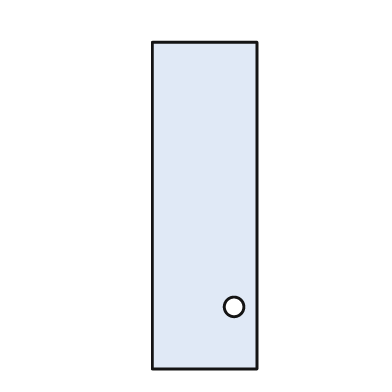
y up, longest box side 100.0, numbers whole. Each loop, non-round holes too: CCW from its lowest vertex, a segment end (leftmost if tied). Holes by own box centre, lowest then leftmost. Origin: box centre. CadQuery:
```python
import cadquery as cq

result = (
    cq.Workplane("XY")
    .moveTo(-16.0, -50.0)
    .lineTo(16.0, -50.0)
    .lineTo(16.0, 50.0)
    .lineTo(-16.0, 50.0)
    .close()
    .moveTo(9.0, -31.0)
    .circle(3.0)
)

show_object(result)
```